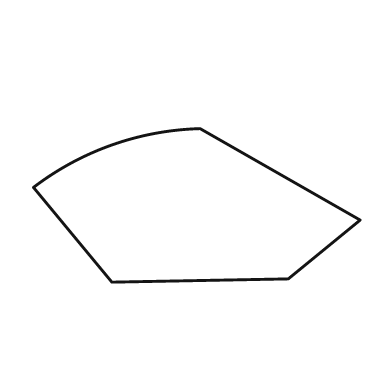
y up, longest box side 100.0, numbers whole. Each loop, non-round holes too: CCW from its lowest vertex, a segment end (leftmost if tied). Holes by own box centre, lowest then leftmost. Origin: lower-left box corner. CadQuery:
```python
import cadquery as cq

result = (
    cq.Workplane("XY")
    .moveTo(24.0, 0.0)
    .lineTo(78.0, 1.0)
    .lineTo(100.0, 19.0)
    .lineTo(51.0, 47.0)
    .threePointArc((24.0, 42.0), (0.0, 29.0))
    .close()
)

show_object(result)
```